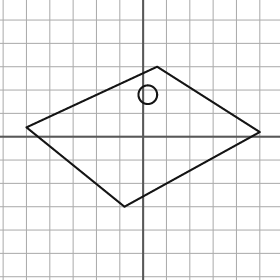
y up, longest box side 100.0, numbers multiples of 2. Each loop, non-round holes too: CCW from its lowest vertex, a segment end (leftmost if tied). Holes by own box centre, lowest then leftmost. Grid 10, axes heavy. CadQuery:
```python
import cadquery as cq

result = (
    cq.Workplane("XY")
    .moveTo(-8.0, -30.0)
    .lineTo(50.0, 2.0)
    .lineTo(6.0, 30.0)
    .lineTo(-50.0, 4.0)
    .close()
    .moveTo(2.0, 18.0)
    .circle(4.0)
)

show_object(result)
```